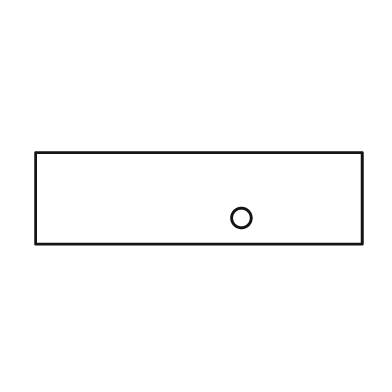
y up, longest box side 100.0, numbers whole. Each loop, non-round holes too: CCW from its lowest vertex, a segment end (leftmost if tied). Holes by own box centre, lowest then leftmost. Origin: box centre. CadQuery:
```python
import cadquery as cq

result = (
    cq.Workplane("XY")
    .moveTo(-50.0, -14.0)
    .lineTo(50.0, -14.0)
    .lineTo(50.0, 14.0)
    .lineTo(-50.0, 14.0)
    .close()
    .moveTo(13.0, -6.0)
    .circle(3.0)
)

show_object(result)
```